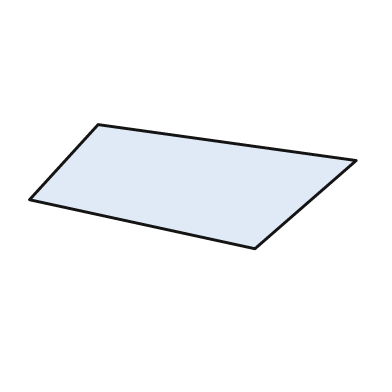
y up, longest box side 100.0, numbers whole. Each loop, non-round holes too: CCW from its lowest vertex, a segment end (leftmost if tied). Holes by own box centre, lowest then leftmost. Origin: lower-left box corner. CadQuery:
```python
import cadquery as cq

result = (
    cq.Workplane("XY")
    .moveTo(69.0, 0.0)
    .lineTo(100.0, 27.0)
    .lineTo(21.0, 38.0)
    .lineTo(0.0, 15.0)
    .close()
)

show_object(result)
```